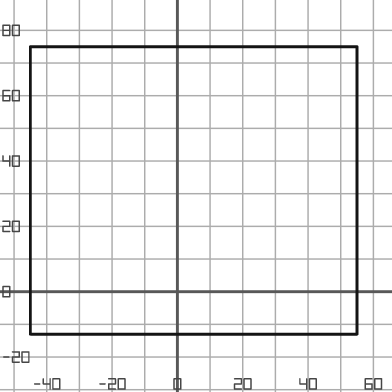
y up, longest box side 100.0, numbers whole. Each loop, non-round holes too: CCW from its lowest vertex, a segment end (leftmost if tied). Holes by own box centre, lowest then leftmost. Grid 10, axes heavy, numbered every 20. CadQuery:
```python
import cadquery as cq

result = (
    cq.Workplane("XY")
    .moveTo(-45.0, -13.0)
    .lineTo(55.0, -13.0)
    .lineTo(55.0, 75.0)
    .lineTo(-45.0, 75.0)
    .close()
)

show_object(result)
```